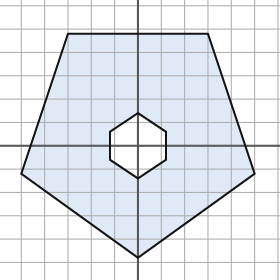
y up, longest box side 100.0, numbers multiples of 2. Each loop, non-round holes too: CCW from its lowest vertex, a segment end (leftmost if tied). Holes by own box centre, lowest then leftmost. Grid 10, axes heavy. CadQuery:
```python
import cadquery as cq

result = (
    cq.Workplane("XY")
    .moveTo(0.0, -48.0)
    .lineTo(50.0, -12.0)
    .lineTo(30.0, 48.0)
    .lineTo(-30.0, 48.0)
    .lineTo(-50.0, -12.0)
    .close()
    .moveTo(0.0, -14.0)
    .lineTo(12.0, -6.0)
    .lineTo(12.0, 6.0)
    .lineTo(0.0, 14.0)
    .lineTo(-12.0, 6.0)
    .lineTo(-12.0, -6.0)
    .close()
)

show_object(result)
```